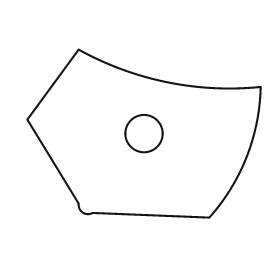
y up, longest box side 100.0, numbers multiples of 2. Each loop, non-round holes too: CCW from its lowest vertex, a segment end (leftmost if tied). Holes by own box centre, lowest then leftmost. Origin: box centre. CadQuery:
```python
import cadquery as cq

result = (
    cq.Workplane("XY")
    .moveTo(28.0, -36.0)
    .threePointArc((44.0, -10.0), (50.0, 20.0))
    .threePointArc((10.0, 22.0), (-28.0, 36.0))
    .lineTo(-50.0, 6.0)
    .lineTo(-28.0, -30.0)
    .threePointArc((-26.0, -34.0), (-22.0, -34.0))
    .close()
    .moveTo(0.0, 0.0)
    .circle(8.0)
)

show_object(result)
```